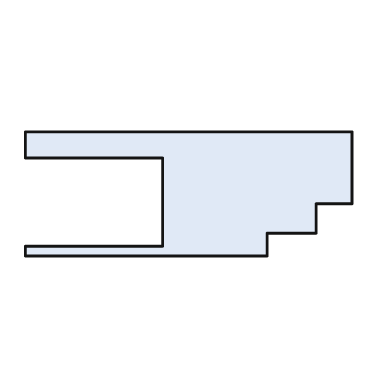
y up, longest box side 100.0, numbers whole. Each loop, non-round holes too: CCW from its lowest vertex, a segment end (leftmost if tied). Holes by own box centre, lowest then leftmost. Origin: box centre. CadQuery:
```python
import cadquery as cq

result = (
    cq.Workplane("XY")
    .moveTo(-50.0, -19.0)
    .lineTo(24.0, -19.0)
    .lineTo(24.0, -12.0)
    .lineTo(39.0, -12.0)
    .lineTo(39.0, -3.0)
    .lineTo(50.0, -3.0)
    .lineTo(50.0, 19.0)
    .lineTo(-50.0, 19.0)
    .lineTo(-50.0, 11.0)
    .lineTo(-8.0, 11.0)
    .lineTo(-8.0, -16.0)
    .lineTo(-50.0, -16.0)
    .close()
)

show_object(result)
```